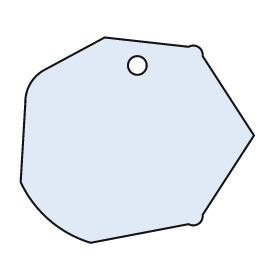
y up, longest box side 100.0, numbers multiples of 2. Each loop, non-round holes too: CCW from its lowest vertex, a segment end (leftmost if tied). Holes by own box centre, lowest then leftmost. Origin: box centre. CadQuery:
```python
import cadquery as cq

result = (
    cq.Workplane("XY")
    .moveTo(-20.0, -44.0)
    .lineTo(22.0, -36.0)
    .threePointArc((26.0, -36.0), (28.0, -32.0))
    .lineTo(50.0, 2.0)
    .lineTo(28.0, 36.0)
    .threePointArc((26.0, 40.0), (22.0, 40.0))
    .lineTo(-14.0, 44.0)
    .lineTo(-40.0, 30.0)
    .threePointArc((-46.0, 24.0), (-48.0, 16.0))
    .lineTo(-50.0, -18.0)
    .threePointArc((-38.0, -34.0), (-20.0, -44.0))
    .close()
    .moveTo(0.0, 32.0)
    .circle(4.0)
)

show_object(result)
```